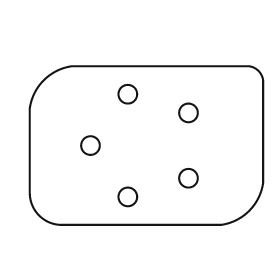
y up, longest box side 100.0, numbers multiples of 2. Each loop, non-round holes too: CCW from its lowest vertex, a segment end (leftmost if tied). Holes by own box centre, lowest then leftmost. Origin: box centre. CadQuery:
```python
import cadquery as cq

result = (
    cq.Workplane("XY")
    .moveTo(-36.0, -34.0)
    .lineTo(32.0, -34.0)
    .threePointArc((44.0, -28.0), (50.0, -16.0))
    .lineTo(50.0, 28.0)
    .threePointArc((48.0, 32.0), (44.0, 34.0))
    .lineTo(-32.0, 34.0)
    .threePointArc((-44.0, 28.0), (-50.0, 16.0))
    .lineTo(-50.0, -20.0)
    .threePointArc((-46.0, -30.0), (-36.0, -34.0))
    .close()
    .moveTo(-8.0, -22.0)
    .circle(4.0)
    .moveTo(18.0, -14.0)
    .circle(4.0)
    .moveTo(-24.0, 0.0)
    .circle(4.0)
    .moveTo(18.0, 14.0)
    .circle(4.0)
    .moveTo(-8.0, 22.0)
    .circle(4.0)
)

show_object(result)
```